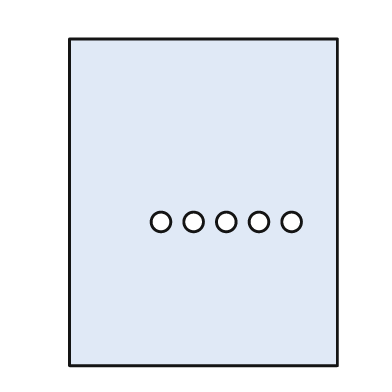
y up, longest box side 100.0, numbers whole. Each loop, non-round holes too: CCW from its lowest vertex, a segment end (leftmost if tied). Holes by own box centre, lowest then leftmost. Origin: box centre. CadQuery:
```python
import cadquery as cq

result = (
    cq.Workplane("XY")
    .moveTo(-41.0, -50.0)
    .lineTo(41.0, -50.0)
    .lineTo(41.0, 50.0)
    .lineTo(-41.0, 50.0)
    .close()
    .moveTo(-13.0, -6.0)
    .circle(3.0)
    .moveTo(-3.0, -6.0)
    .circle(3.0)
    .moveTo(7.0, -6.0)
    .circle(3.0)
    .moveTo(17.0, -6.0)
    .circle(3.0)
    .moveTo(27.0, -6.0)
    .circle(3.0)
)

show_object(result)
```